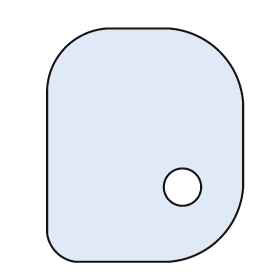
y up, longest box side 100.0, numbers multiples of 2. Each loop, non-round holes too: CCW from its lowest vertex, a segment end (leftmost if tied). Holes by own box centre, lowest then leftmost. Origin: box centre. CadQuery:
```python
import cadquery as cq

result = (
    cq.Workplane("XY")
    .moveTo(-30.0, -50.0)
    .lineTo(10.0, -50.0)
    .threePointArc((32.0, -40.0), (42.0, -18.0))
    .lineTo(42.0, 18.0)
    .threePointArc((32.0, 40.0), (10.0, 50.0))
    .lineTo(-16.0, 50.0)
    .threePointArc((-34.0, 42.0), (-42.0, 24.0))
    .lineTo(-42.0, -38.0)
    .threePointArc((-38.0, -46.0), (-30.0, -50.0))
    .close()
    .moveTo(16.0, -18.0)
    .circle(8.0)
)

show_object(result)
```